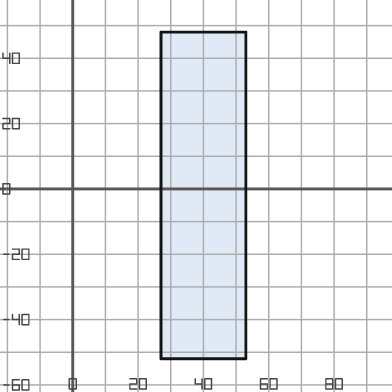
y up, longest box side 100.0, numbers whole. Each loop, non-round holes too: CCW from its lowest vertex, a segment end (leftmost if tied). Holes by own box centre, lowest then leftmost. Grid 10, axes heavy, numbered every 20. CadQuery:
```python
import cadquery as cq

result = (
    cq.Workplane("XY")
    .moveTo(27.0, -52.0)
    .lineTo(53.0, -52.0)
    .lineTo(53.0, 48.0)
    .lineTo(27.0, 48.0)
    .close()
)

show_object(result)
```